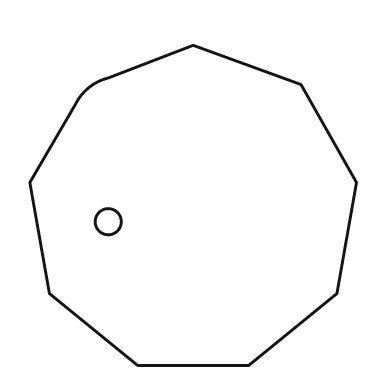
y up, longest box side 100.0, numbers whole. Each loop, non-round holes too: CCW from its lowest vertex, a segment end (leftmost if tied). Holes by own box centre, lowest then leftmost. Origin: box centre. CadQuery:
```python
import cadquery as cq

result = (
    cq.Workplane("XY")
    .moveTo(-17.0, -49.0)
    .lineTo(17.0, -49.0)
    .lineTo(44.0, -27.0)
    .lineTo(50.0, 7.0)
    .lineTo(33.0, 37.0)
    .lineTo(0.0, 49.0)
    .lineTo(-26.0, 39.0)
    .threePointArc((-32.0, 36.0), (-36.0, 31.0))
    .lineTo(-50.0, 7.0)
    .lineTo(-44.0, -27.0)
    .close()
    .moveTo(-26.0, -5.0)
    .circle(4.0)
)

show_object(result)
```